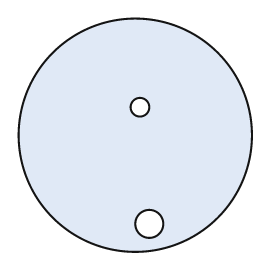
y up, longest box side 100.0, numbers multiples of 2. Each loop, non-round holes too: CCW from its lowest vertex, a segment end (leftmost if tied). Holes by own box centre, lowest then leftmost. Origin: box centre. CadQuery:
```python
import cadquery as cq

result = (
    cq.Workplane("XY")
    .moveTo(0.0, 0.0)
    .circle(50.0)
    .moveTo(6.0, -38.0)
    .circle(6.0)
    .moveTo(2.0, 12.0)
    .circle(4.0)
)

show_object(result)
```